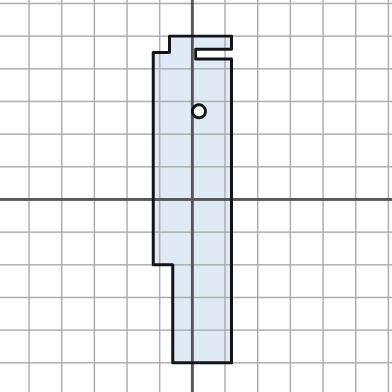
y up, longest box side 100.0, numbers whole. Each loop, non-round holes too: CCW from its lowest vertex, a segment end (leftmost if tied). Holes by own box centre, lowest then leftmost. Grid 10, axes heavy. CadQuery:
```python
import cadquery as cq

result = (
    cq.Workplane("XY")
    .moveTo(-6.0, -50.0)
    .lineTo(12.0, -50.0)
    .lineTo(12.0, 43.0)
    .lineTo(1.0, 43.0)
    .lineTo(1.0, 46.0)
    .lineTo(12.0, 46.0)
    .lineTo(12.0, 50.0)
    .lineTo(-7.0, 50.0)
    .lineTo(-7.0, 45.0)
    .lineTo(-12.0, 45.0)
    .lineTo(-12.0, -20.0)
    .lineTo(-6.0, -20.0)
    .close()
    .moveTo(2.0, 27.0)
    .circle(2.0)
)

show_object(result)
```